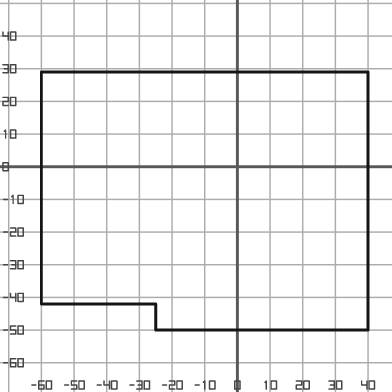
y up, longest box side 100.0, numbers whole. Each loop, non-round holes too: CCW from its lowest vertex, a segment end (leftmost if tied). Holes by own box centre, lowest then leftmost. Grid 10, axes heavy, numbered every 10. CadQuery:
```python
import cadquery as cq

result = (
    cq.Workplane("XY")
    .moveTo(-25.0, -50.0)
    .lineTo(40.0, -50.0)
    .lineTo(40.0, 29.0)
    .lineTo(-60.0, 29.0)
    .lineTo(-60.0, -42.0)
    .lineTo(-25.0, -42.0)
    .close()
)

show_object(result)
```